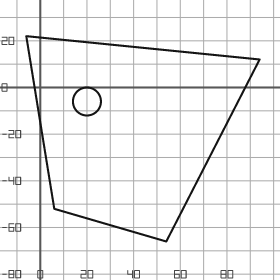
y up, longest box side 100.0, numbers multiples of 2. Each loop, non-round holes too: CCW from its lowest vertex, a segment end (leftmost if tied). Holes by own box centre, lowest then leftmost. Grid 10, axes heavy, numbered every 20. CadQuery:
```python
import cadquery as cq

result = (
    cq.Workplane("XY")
    .moveTo(54.0, -66.0)
    .lineTo(94.0, 12.0)
    .lineTo(-6.0, 22.0)
    .lineTo(6.0, -52.0)
    .close()
    .moveTo(20.0, -6.0)
    .circle(6.0)
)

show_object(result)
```